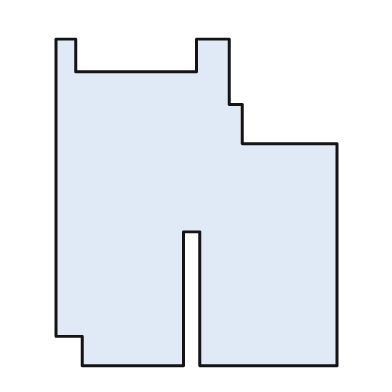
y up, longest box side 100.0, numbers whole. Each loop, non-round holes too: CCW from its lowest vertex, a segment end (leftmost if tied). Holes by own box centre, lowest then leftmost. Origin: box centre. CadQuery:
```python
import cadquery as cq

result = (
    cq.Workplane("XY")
    .moveTo(-35.0, -50.0)
    .lineTo(-4.0, -50.0)
    .lineTo(-4.0, -9.0)
    .lineTo(1.0, -9.0)
    .lineTo(1.0, -50.0)
    .lineTo(43.0, -50.0)
    .lineTo(43.0, 18.0)
    .lineTo(14.0, 18.0)
    .lineTo(14.0, 30.0)
    .lineTo(10.0, 30.0)
    .lineTo(10.0, 50.0)
    .lineTo(0.0, 50.0)
    .lineTo(0.0, 40.0)
    .lineTo(-37.0, 40.0)
    .lineTo(-37.0, 50.0)
    .lineTo(-43.0, 50.0)
    .lineTo(-43.0, -41.0)
    .lineTo(-35.0, -41.0)
    .close()
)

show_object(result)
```